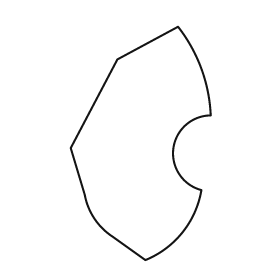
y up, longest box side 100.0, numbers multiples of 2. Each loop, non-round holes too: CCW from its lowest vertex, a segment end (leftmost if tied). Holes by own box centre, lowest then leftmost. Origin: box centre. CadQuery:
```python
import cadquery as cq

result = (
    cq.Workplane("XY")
    .moveTo(2.0, -50.0)
    .threePointArc((18.0, -38.0), (26.0, -20.0))
    .threePointArc((14.0, -2.0), (30.0, 12.0))
    .threePointArc((26.0, 32.0), (16.0, 50.0))
    .lineTo(-10.0, 36.0)
    .lineTo(-30.0, -2.0)
    .lineTo(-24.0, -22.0)
    .threePointArc((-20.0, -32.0), (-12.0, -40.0))
    .close()
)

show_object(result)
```